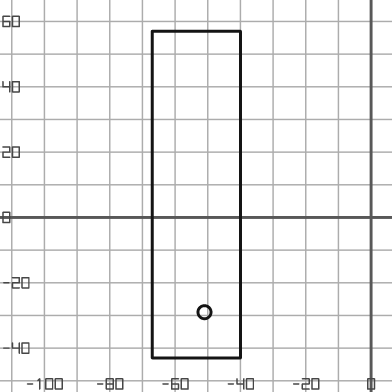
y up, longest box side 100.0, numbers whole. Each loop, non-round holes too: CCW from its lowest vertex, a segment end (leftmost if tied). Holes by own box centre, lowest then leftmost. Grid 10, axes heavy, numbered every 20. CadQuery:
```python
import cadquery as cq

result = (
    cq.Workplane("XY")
    .moveTo(-67.0, -43.0)
    .lineTo(-40.0, -43.0)
    .lineTo(-40.0, 57.0)
    .lineTo(-67.0, 57.0)
    .close()
    .moveTo(-51.0, -29.0)
    .circle(2.0)
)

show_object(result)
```